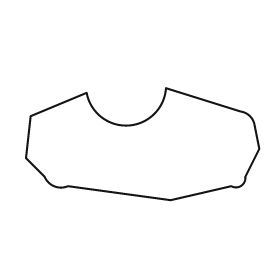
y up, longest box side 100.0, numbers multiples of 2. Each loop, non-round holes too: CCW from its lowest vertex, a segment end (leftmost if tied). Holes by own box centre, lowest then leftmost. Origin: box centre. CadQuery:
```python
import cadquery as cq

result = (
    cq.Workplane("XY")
    .moveTo(12.0, -24.0)
    .lineTo(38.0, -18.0)
    .threePointArc((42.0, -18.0), (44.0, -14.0))
    .lineTo(50.0, -2.0)
    .lineTo(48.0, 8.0)
    .threePointArc((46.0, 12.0), (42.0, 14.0))
    .lineTo(10.0, 24.0)
    .threePointArc((-6.0, 8.0), (-24.0, 22.0))
    .lineTo(-48.0, 12.0)
    .lineTo(-50.0, -6.0)
    .lineTo(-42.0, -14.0)
    .threePointArc((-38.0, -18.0), (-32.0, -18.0))
    .close()
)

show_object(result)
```